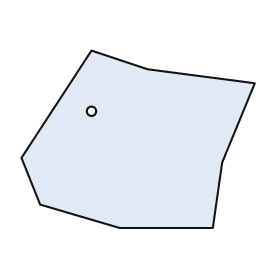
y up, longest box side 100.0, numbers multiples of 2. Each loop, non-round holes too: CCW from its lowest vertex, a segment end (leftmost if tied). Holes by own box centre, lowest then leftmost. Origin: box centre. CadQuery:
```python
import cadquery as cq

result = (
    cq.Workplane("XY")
    .moveTo(-8.0, -38.0)
    .lineTo(32.0, -38.0)
    .lineTo(36.0, -10.0)
    .lineTo(50.0, 24.0)
    .lineTo(4.0, 30.0)
    .lineTo(-20.0, 38.0)
    .lineTo(-50.0, -8.0)
    .lineTo(-42.0, -28.0)
    .close()
    .moveTo(-20.0, 12.0)
    .circle(2.0)
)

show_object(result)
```